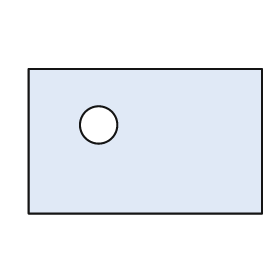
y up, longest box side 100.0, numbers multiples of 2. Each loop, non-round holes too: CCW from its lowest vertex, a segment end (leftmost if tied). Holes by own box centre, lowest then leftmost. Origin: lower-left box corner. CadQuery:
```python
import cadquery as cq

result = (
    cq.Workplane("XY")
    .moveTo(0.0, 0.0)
    .lineTo(100.0, 0.0)
    .lineTo(100.0, 62.0)
    .lineTo(0.0, 62.0)
    .close()
    .moveTo(30.0, 38.0)
    .circle(8.0)
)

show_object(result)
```